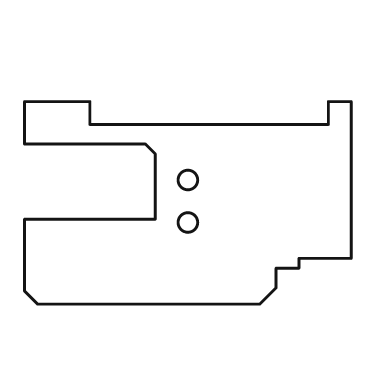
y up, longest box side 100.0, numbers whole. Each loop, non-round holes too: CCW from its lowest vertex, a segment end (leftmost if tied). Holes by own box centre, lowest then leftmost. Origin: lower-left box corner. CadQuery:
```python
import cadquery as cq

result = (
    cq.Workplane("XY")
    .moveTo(4.0, 0.0)
    .lineTo(72.0, 0.0)
    .lineTo(77.0, 5.0)
    .lineTo(77.0, 11.0)
    .lineTo(84.0, 11.0)
    .lineTo(84.0, 14.0)
    .lineTo(100.0, 14.0)
    .lineTo(100.0, 62.0)
    .lineTo(93.0, 62.0)
    .lineTo(93.0, 55.0)
    .lineTo(20.0, 55.0)
    .lineTo(20.0, 62.0)
    .lineTo(0.0, 62.0)
    .lineTo(0.0, 49.0)
    .lineTo(37.0, 49.0)
    .lineTo(40.0, 46.0)
    .lineTo(40.0, 26.0)
    .lineTo(0.0, 26.0)
    .lineTo(0.0, 4.0)
    .close()
    .moveTo(50.0, 25.0)
    .circle(3.0)
    .moveTo(50.0, 38.0)
    .circle(3.0)
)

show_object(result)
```